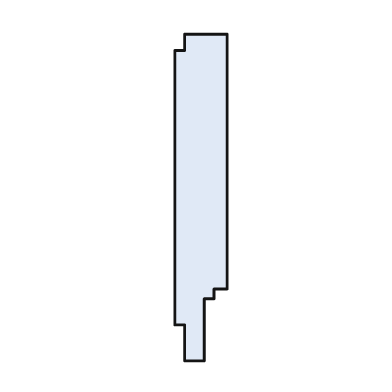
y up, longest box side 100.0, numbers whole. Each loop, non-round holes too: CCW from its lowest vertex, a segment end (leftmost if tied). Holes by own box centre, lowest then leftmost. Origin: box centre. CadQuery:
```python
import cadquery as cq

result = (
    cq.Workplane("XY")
    .moveTo(-5.0, -50.0)
    .lineTo(1.0, -50.0)
    .lineTo(1.0, -31.0)
    .lineTo(4.0, -31.0)
    .lineTo(4.0, -28.0)
    .lineTo(8.0, -28.0)
    .lineTo(8.0, 50.0)
    .lineTo(-5.0, 50.0)
    .lineTo(-5.0, 45.0)
    .lineTo(-8.0, 45.0)
    .lineTo(-8.0, -39.0)
    .lineTo(-5.0, -39.0)
    .close()
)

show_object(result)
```